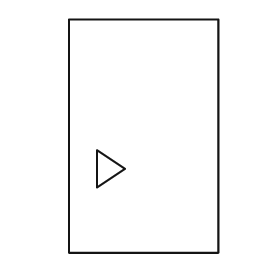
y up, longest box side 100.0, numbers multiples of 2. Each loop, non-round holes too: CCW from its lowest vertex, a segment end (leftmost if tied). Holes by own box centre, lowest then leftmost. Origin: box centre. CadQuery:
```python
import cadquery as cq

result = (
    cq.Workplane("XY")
    .moveTo(-32.0, -50.0)
    .lineTo(32.0, -50.0)
    .lineTo(32.0, 50.0)
    .lineTo(-32.0, 50.0)
    .close()
    .moveTo(-20.0, -22.0)
    .lineTo(-8.0, -14.0)
    .lineTo(-20.0, -6.0)
    .close()
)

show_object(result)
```